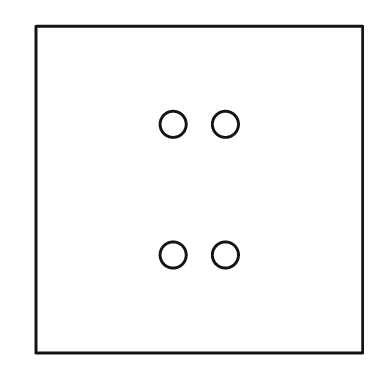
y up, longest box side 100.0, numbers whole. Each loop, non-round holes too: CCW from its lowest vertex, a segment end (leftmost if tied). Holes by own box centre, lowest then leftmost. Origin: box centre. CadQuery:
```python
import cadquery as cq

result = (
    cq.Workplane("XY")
    .moveTo(-50.0, -50.0)
    .lineTo(50.0, -50.0)
    .lineTo(50.0, 50.0)
    .lineTo(-50.0, 50.0)
    .close()
    .moveTo(-8.0, -20.0)
    .circle(4.0)
    .moveTo(8.0, -20.0)
    .circle(4.0)
    .moveTo(-8.0, 20.0)
    .circle(4.0)
    .moveTo(8.0, 20.0)
    .circle(4.0)
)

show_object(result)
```